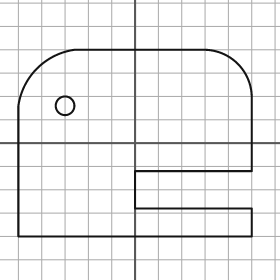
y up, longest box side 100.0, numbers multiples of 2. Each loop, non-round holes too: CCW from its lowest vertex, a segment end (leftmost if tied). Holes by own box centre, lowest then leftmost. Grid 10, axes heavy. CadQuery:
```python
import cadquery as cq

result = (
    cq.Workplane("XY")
    .moveTo(-50.0, -40.0)
    .lineTo(50.0, -40.0)
    .lineTo(50.0, -28.0)
    .lineTo(0.0, -28.0)
    .lineTo(0.0, -12.0)
    .lineTo(50.0, -12.0)
    .lineTo(50.0, 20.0)
    .threePointArc((44.0, 34.0), (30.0, 40.0))
    .lineTo(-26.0, 40.0)
    .threePointArc((-42.0, 32.0), (-50.0, 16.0))
    .close()
    .moveTo(-30.0, 16.0)
    .circle(4.0)
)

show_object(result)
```